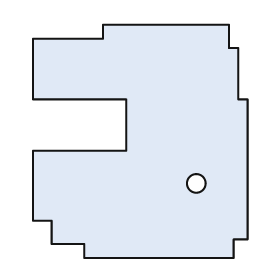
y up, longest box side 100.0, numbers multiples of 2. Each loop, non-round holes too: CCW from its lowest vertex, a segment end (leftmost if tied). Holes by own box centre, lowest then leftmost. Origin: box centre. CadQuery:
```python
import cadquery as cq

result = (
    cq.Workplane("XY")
    .moveTo(-24.0, -50.0)
    .lineTo(40.0, -50.0)
    .lineTo(40.0, -42.0)
    .lineTo(46.0, -42.0)
    .lineTo(46.0, 18.0)
    .lineTo(42.0, 18.0)
    .lineTo(42.0, 40.0)
    .lineTo(38.0, 40.0)
    .lineTo(38.0, 50.0)
    .lineTo(-16.0, 50.0)
    .lineTo(-16.0, 44.0)
    .lineTo(-46.0, 44.0)
    .lineTo(-46.0, 18.0)
    .lineTo(-6.0, 18.0)
    .lineTo(-6.0, -4.0)
    .lineTo(-46.0, -4.0)
    .lineTo(-46.0, -34.0)
    .lineTo(-38.0, -34.0)
    .lineTo(-38.0, -44.0)
    .lineTo(-24.0, -44.0)
    .close()
    .moveTo(24.0, -18.0)
    .circle(4.0)
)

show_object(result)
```